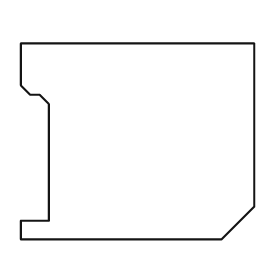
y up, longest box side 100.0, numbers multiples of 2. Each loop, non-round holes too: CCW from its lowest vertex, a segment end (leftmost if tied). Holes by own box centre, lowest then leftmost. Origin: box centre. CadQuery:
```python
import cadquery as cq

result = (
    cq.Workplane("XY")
    .moveTo(-50.0, -42.0)
    .lineTo(36.0, -42.0)
    .lineTo(50.0, -28.0)
    .lineTo(50.0, 42.0)
    .lineTo(-50.0, 42.0)
    .lineTo(-50.0, 24.0)
    .lineTo(-46.0, 20.0)
    .lineTo(-42.0, 20.0)
    .lineTo(-38.0, 16.0)
    .lineTo(-38.0, -34.0)
    .lineTo(-50.0, -34.0)
    .close()
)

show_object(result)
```